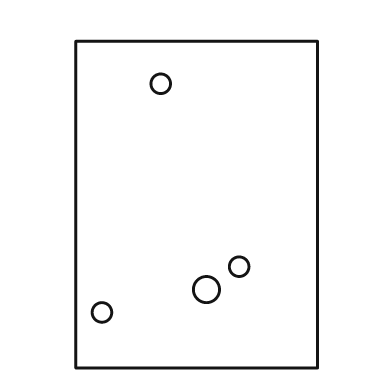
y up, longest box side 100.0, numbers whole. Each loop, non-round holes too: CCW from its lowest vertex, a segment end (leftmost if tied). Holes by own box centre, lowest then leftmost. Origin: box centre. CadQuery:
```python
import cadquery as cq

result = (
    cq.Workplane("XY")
    .moveTo(-37.0, -50.0)
    .lineTo(37.0, -50.0)
    .lineTo(37.0, 50.0)
    .lineTo(-37.0, 50.0)
    .close()
    .moveTo(-29.0, -33.0)
    .circle(3.0)
    .moveTo(3.0, -26.0)
    .circle(4.0)
    .moveTo(13.0, -19.0)
    .circle(3.0)
    .moveTo(-11.0, 37.0)
    .circle(3.0)
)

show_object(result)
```